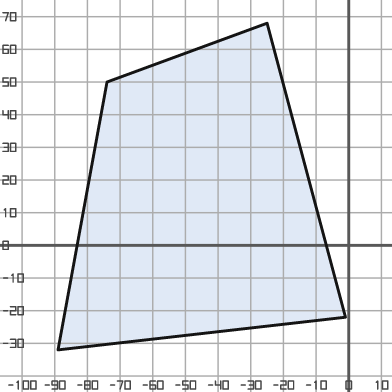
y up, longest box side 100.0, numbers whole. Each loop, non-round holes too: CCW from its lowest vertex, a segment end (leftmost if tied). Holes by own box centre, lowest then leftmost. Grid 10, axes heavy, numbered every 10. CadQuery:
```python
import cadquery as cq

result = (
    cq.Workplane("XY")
    .moveTo(-89.0, -32.0)
    .lineTo(-1.0, -22.0)
    .lineTo(-25.0, 68.0)
    .lineTo(-74.0, 50.0)
    .close()
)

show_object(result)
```